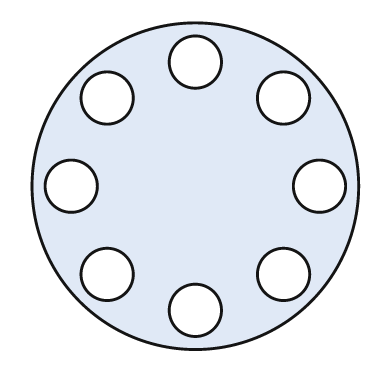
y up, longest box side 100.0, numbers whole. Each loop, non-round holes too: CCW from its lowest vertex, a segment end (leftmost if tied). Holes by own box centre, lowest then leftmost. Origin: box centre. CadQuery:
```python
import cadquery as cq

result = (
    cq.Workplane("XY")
    .moveTo(0.0, 0.0)
    .circle(50.0)
    .moveTo(0.0, -38.0)
    .circle(8.0)
    .moveTo(-27.0, -27.0)
    .circle(8.0)
    .moveTo(27.0, -27.0)
    .circle(8.0)
    .moveTo(-38.0, 0.0)
    .circle(8.0)
    .moveTo(38.0, 0.0)
    .circle(8.0)
    .moveTo(-27.0, 27.0)
    .circle(8.0)
    .moveTo(27.0, 27.0)
    .circle(8.0)
    .moveTo(0.0, 38.0)
    .circle(8.0)
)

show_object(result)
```